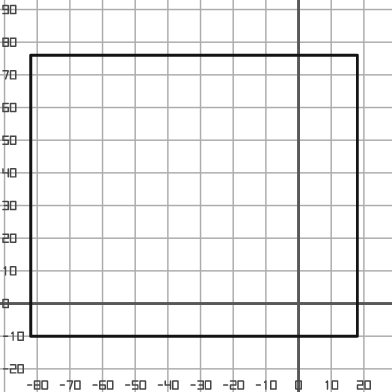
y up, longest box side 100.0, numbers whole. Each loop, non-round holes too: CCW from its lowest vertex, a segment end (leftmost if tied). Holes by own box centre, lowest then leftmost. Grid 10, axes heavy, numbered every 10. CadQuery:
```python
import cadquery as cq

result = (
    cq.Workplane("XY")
    .moveTo(-82.0, -10.0)
    .lineTo(18.0, -10.0)
    .lineTo(18.0, 76.0)
    .lineTo(-82.0, 76.0)
    .close()
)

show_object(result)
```